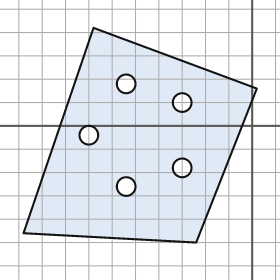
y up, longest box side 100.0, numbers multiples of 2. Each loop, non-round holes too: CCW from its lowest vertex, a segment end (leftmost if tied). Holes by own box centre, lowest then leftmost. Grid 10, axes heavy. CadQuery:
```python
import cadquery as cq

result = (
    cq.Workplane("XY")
    .moveTo(-24.0, -50.0)
    .lineTo(2.0, 16.0)
    .lineTo(-68.0, 42.0)
    .lineTo(-98.0, -46.0)
    .close()
    .moveTo(-54.0, -26.0)
    .circle(4.0)
    .moveTo(-30.0, -18.0)
    .circle(4.0)
    .moveTo(-70.0, -4.0)
    .circle(4.0)
    .moveTo(-30.0, 10.0)
    .circle(4.0)
    .moveTo(-54.0, 18.0)
    .circle(4.0)
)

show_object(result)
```